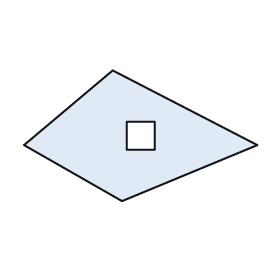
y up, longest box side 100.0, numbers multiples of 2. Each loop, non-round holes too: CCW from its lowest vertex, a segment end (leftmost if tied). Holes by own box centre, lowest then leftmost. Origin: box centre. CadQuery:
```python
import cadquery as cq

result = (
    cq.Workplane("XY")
    .moveTo(-8.0, -28.0)
    .lineTo(50.0, -4.0)
    .lineTo(-12.0, 28.0)
    .lineTo(-50.0, -4.0)
    .close()
    .moveTo(-6.0, -6.0)
    .lineTo(6.0, -6.0)
    .lineTo(6.0, 6.0)
    .lineTo(-6.0, 6.0)
    .close()
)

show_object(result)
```